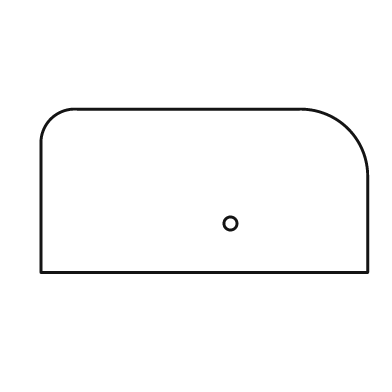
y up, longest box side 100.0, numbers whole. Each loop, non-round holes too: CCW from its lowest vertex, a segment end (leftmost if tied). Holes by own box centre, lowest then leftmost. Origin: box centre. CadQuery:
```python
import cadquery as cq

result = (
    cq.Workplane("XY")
    .moveTo(-50.0, -25.0)
    .lineTo(50.0, -25.0)
    .lineTo(50.0, 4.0)
    .threePointArc((44.0, 19.0), (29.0, 25.0))
    .lineTo(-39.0, 25.0)
    .threePointArc((-47.0, 22.0), (-50.0, 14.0))
    .close()
    .moveTo(8.0, -10.0)
    .circle(2.0)
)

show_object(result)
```